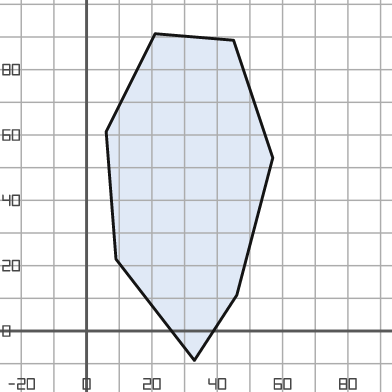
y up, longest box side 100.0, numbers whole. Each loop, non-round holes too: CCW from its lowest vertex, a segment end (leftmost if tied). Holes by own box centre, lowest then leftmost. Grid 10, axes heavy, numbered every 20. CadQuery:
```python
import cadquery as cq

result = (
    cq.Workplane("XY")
    .moveTo(33.0, -9.0)
    .lineTo(46.0, 11.0)
    .lineTo(57.0, 53.0)
    .lineTo(45.0, 89.0)
    .lineTo(21.0, 91.0)
    .lineTo(6.0, 61.0)
    .lineTo(9.0, 22.0)
    .close()
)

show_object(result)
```